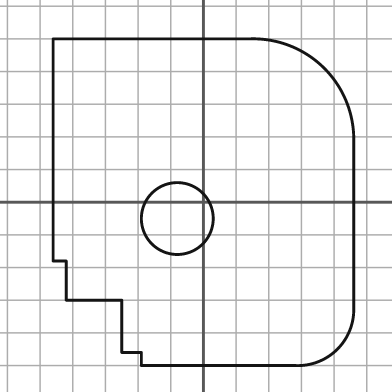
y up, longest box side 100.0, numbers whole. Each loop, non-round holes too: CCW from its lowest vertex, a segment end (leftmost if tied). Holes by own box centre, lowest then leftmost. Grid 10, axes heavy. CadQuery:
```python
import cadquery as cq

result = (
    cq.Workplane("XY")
    .moveTo(-19.0, -50.0)
    .lineTo(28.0, -50.0)
    .threePointArc((41.0, -45.0), (46.0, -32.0))
    .lineTo(46.0, 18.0)
    .threePointArc((37.0, 41.0), (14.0, 50.0))
    .lineTo(-46.0, 50.0)
    .lineTo(-46.0, -18.0)
    .lineTo(-42.0, -18.0)
    .lineTo(-42.0, -30.0)
    .lineTo(-25.0, -30.0)
    .lineTo(-25.0, -46.0)
    .lineTo(-19.0, -46.0)
    .close()
    .moveTo(-8.0, -5.0)
    .circle(11.0)
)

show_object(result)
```